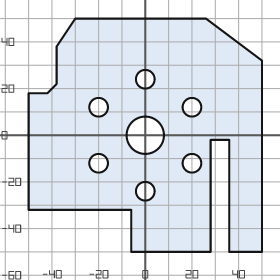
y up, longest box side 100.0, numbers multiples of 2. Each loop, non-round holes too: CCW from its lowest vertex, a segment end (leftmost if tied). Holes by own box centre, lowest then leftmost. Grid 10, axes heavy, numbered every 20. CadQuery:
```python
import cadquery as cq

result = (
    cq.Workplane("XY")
    .moveTo(-6.0, -50.0)
    .lineTo(28.0, -50.0)
    .lineTo(28.0, -2.0)
    .lineTo(36.0, -2.0)
    .lineTo(36.0, -50.0)
    .lineTo(50.0, -50.0)
    .lineTo(50.0, 32.0)
    .lineTo(26.0, 50.0)
    .lineTo(-30.0, 50.0)
    .lineTo(-38.0, 38.0)
    .lineTo(-38.0, 22.0)
    .lineTo(-42.0, 18.0)
    .lineTo(-50.0, 18.0)
    .lineTo(-50.0, -32.0)
    .lineTo(-6.0, -32.0)
    .close()
    .moveTo(0.0, -24.0)
    .circle(4.0)
    .moveTo(-20.0, -12.0)
    .circle(4.0)
    .moveTo(20.0, -12.0)
    .circle(4.0)
    .moveTo(0.0, 0.0)
    .circle(8.0)
    .moveTo(-20.0, 12.0)
    .circle(4.0)
    .moveTo(20.0, 12.0)
    .circle(4.0)
    .moveTo(0.0, 24.0)
    .circle(4.0)
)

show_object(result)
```